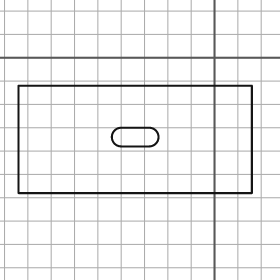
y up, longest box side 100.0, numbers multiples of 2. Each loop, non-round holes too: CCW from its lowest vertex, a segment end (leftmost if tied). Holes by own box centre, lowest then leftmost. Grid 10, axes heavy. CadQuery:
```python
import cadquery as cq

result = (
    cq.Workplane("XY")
    .moveTo(-84.0, -58.0)
    .lineTo(16.0, -58.0)
    .lineTo(16.0, -12.0)
    .lineTo(-84.0, -12.0)
    .close()
    .moveTo(-40.0, -38.0)
    .lineTo(-28.0, -38.0)
    .threePointArc((-24.0, -34.0), (-28.0, -30.0))
    .lineTo(-40.0, -30.0)
    .threePointArc((-44.0, -34.0), (-40.0, -38.0))
    .close()
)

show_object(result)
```